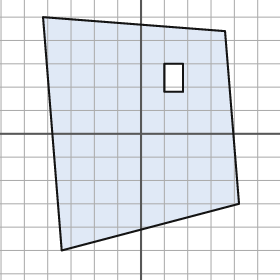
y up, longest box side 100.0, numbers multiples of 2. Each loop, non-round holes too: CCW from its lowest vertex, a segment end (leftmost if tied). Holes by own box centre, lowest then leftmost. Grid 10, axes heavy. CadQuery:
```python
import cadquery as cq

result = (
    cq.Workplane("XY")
    .moveTo(-34.0, -50.0)
    .lineTo(42.0, -30.0)
    .lineTo(36.0, 44.0)
    .lineTo(-42.0, 50.0)
    .close()
    .moveTo(10.0, 18.0)
    .lineTo(18.0, 18.0)
    .lineTo(18.0, 30.0)
    .lineTo(10.0, 30.0)
    .close()
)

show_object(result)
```